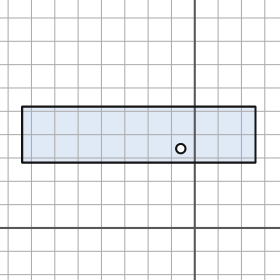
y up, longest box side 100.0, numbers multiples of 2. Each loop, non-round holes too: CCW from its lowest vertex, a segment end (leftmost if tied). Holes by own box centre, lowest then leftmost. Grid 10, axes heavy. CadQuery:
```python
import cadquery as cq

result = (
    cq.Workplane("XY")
    .moveTo(-74.0, 28.0)
    .lineTo(26.0, 28.0)
    .lineTo(26.0, 52.0)
    .lineTo(-74.0, 52.0)
    .close()
    .moveTo(-6.0, 34.0)
    .circle(2.0)
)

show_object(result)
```